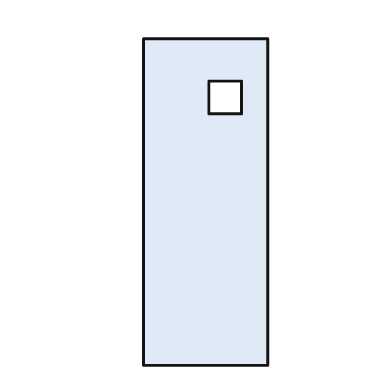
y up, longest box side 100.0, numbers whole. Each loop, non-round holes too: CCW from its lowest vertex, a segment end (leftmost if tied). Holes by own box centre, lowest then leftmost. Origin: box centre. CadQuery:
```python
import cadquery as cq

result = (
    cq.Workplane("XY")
    .moveTo(-19.0, -50.0)
    .lineTo(19.0, -50.0)
    .lineTo(19.0, 50.0)
    .lineTo(-19.0, 50.0)
    .close()
    .moveTo(1.0, 27.0)
    .lineTo(11.0, 27.0)
    .lineTo(11.0, 37.0)
    .lineTo(1.0, 37.0)
    .close()
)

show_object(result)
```